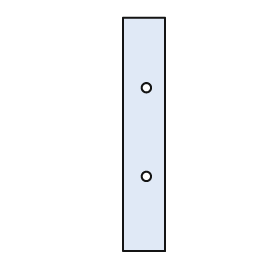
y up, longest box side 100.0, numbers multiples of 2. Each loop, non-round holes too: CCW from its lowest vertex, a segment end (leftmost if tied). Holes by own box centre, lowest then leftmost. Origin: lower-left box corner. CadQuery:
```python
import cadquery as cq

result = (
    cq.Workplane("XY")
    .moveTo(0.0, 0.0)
    .lineTo(18.0, 0.0)
    .lineTo(18.0, 100.0)
    .lineTo(0.0, 100.0)
    .close()
    .moveTo(10.0, 32.0)
    .circle(2.0)
    .moveTo(10.0, 70.0)
    .circle(2.0)
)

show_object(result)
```